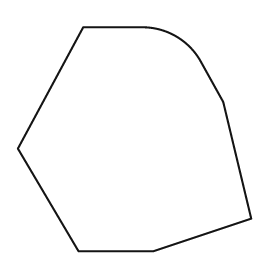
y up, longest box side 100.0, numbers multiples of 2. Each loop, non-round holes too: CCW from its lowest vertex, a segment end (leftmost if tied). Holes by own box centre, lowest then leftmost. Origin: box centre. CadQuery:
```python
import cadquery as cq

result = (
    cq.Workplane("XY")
    .moveTo(-24.0, -48.0)
    .lineTo(8.0, -48.0)
    .lineTo(50.0, -34.0)
    .lineTo(38.0, 16.0)
    .lineTo(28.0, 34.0)
    .threePointArc((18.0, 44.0), (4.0, 48.0))
    .lineTo(-22.0, 48.0)
    .lineTo(-50.0, -4.0)
    .close()
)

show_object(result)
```